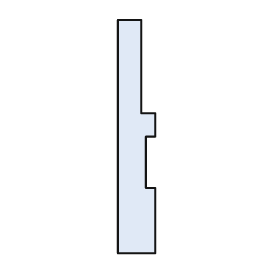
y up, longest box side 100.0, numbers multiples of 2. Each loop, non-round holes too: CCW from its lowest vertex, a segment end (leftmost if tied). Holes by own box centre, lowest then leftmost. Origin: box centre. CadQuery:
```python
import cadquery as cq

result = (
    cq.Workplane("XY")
    .moveTo(-8.0, -50.0)
    .lineTo(8.0, -50.0)
    .lineTo(8.0, -22.0)
    .lineTo(4.0, -22.0)
    .lineTo(4.0, 0.0)
    .lineTo(8.0, 0.0)
    .lineTo(8.0, 10.0)
    .lineTo(2.0, 10.0)
    .lineTo(2.0, 50.0)
    .lineTo(-8.0, 50.0)
    .close()
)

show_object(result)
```